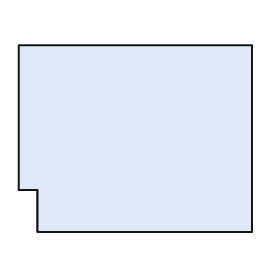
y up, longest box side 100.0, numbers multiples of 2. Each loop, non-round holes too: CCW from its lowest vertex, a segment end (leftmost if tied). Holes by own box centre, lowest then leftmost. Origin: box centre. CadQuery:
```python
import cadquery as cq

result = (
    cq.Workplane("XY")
    .moveTo(-42.0, -40.0)
    .lineTo(50.0, -40.0)
    .lineTo(50.0, 40.0)
    .lineTo(-50.0, 40.0)
    .lineTo(-50.0, -22.0)
    .lineTo(-42.0, -22.0)
    .close()
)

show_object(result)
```